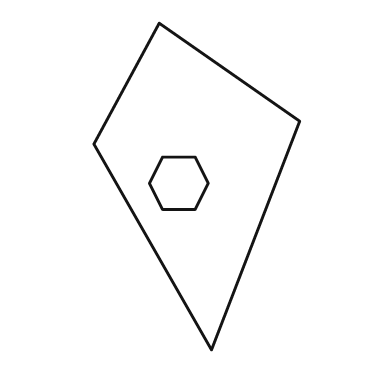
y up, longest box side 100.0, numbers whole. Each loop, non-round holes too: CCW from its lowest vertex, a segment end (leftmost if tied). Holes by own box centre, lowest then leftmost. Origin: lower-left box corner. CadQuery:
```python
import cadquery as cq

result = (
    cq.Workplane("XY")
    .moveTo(36.0, 0.0)
    .lineTo(63.0, 70.0)
    .lineTo(20.0, 100.0)
    .lineTo(0.0, 63.0)
    .close()
    .moveTo(21.0, 43.0)
    .lineTo(31.0, 43.0)
    .lineTo(35.0, 51.0)
    .lineTo(31.0, 59.0)
    .lineTo(21.0, 59.0)
    .lineTo(17.0, 51.0)
    .close()
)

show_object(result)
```